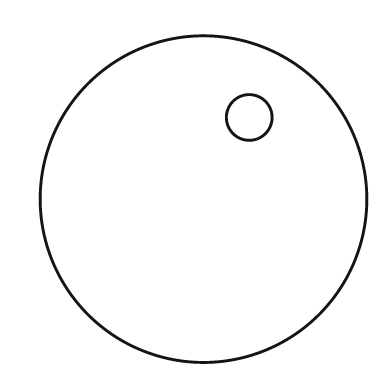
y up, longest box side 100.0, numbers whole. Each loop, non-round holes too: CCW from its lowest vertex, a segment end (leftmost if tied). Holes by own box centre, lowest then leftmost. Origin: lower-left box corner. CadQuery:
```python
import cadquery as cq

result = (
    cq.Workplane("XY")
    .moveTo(50.0, 50.0)
    .circle(50.0)
    .moveTo(64.0, 75.0)
    .circle(7.0)
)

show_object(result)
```